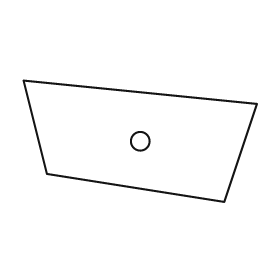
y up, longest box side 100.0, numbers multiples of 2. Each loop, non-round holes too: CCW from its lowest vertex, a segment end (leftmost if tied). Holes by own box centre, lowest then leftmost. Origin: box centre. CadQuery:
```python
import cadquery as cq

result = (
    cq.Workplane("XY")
    .moveTo(36.0, -26.0)
    .lineTo(50.0, 16.0)
    .lineTo(-50.0, 26.0)
    .lineTo(-40.0, -14.0)
    .close()
    .moveTo(0.0, 0.0)
    .circle(4.0)
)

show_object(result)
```